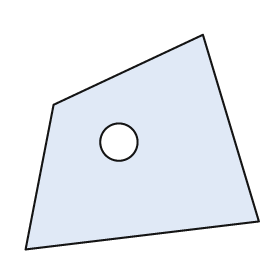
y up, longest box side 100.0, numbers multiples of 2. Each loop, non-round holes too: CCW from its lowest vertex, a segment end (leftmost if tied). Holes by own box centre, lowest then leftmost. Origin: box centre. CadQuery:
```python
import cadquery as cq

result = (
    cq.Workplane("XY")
    .moveTo(-50.0, -46.0)
    .lineTo(50.0, -34.0)
    .lineTo(26.0, 46.0)
    .lineTo(-38.0, 16.0)
    .close()
    .moveTo(-10.0, 0.0)
    .circle(8.0)
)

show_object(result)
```